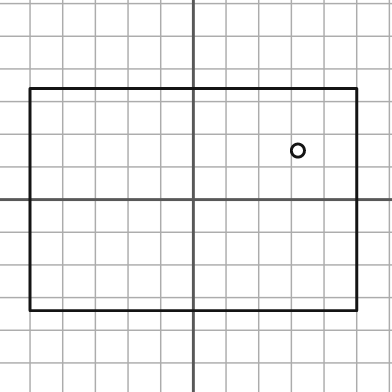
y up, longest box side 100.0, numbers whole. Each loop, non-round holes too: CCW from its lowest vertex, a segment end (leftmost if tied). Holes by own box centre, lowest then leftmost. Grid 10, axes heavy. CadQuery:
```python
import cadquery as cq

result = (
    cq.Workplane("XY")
    .moveTo(-50.0, -34.0)
    .lineTo(50.0, -34.0)
    .lineTo(50.0, 34.0)
    .lineTo(-50.0, 34.0)
    .close()
    .moveTo(32.0, 15.0)
    .circle(2.0)
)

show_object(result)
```